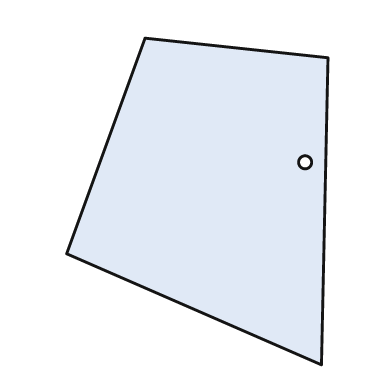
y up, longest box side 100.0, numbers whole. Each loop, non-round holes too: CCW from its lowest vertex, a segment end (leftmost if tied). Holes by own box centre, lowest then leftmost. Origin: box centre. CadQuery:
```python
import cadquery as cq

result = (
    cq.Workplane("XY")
    .moveTo(38.0, -50.0)
    .lineTo(40.0, 44.0)
    .lineTo(-16.0, 50.0)
    .lineTo(-40.0, -16.0)
    .close()
    .moveTo(33.0, 12.0)
    .circle(2.0)
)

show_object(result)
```